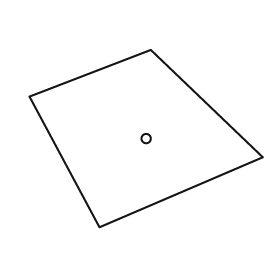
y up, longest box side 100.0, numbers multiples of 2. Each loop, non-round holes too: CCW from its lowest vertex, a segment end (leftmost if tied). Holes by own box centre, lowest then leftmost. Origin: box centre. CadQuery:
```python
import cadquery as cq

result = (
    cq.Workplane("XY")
    .moveTo(-20.0, -38.0)
    .lineTo(50.0, -8.0)
    .lineTo(2.0, 38.0)
    .lineTo(-50.0, 18.0)
    .close()
    .moveTo(0.0, 0.0)
    .circle(2.0)
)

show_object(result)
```